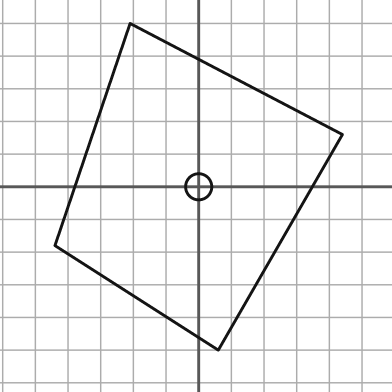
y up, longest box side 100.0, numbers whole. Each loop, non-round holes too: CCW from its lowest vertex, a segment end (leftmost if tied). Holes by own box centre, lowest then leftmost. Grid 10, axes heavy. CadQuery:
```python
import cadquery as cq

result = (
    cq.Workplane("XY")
    .moveTo(6.0, -50.0)
    .lineTo(44.0, 16.0)
    .lineTo(-21.0, 50.0)
    .lineTo(-44.0, -18.0)
    .close()
    .moveTo(0.0, 0.0)
    .circle(4.0)
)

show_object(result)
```